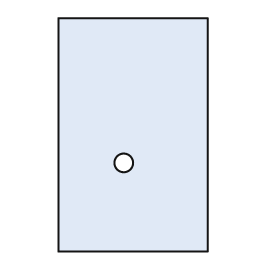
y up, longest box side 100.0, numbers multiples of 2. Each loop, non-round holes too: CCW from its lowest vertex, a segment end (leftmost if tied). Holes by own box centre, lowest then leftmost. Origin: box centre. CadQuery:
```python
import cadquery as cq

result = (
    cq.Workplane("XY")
    .moveTo(-32.0, -50.0)
    .lineTo(32.0, -50.0)
    .lineTo(32.0, 50.0)
    .lineTo(-32.0, 50.0)
    .close()
    .moveTo(-4.0, -12.0)
    .circle(4.0)
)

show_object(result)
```